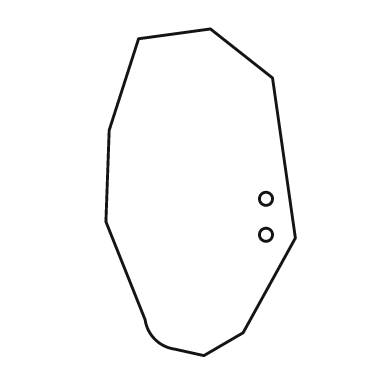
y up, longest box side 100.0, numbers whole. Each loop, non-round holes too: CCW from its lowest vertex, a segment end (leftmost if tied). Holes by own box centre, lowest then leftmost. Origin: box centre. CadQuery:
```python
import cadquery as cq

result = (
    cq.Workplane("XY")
    .moveTo(1.0, -50.0)
    .lineTo(13.0, -43.0)
    .lineTo(29.0, -14.0)
    .lineTo(22.0, 35.0)
    .lineTo(3.0, 50.0)
    .lineTo(-19.0, 47.0)
    .lineTo(-28.0, 19.0)
    .lineTo(-29.0, -9.0)
    .lineTo(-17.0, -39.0)
    .threePointArc((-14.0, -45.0), (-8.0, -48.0))
    .close()
    .moveTo(20.0, -13.0)
    .circle(2.0)
    .moveTo(20.0, -2.0)
    .circle(2.0)
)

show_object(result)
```